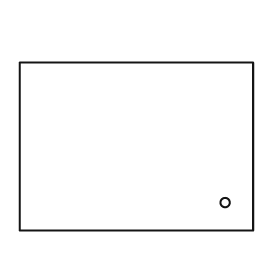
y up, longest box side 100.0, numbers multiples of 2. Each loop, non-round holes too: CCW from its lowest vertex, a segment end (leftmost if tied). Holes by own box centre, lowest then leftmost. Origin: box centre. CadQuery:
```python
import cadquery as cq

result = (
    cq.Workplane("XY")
    .moveTo(-50.0, -36.0)
    .lineTo(50.0, -36.0)
    .lineTo(50.0, 36.0)
    .lineTo(-50.0, 36.0)
    .close()
    .moveTo(38.0, -24.0)
    .circle(2.0)
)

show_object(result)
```